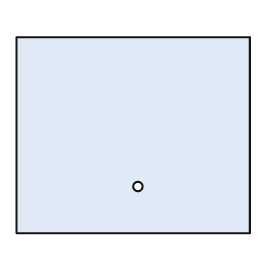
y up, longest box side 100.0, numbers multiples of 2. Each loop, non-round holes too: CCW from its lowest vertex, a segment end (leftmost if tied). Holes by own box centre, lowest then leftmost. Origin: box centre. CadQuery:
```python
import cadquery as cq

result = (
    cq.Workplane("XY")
    .moveTo(-50.0, -42.0)
    .lineTo(50.0, -42.0)
    .lineTo(50.0, 42.0)
    .lineTo(-50.0, 42.0)
    .close()
    .moveTo(2.0, -22.0)
    .circle(2.0)
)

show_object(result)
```